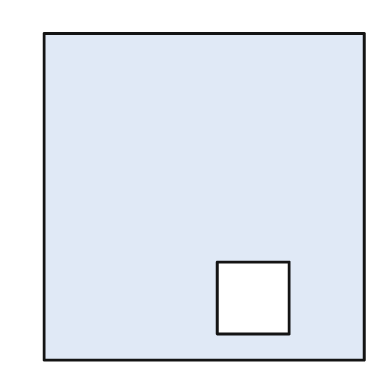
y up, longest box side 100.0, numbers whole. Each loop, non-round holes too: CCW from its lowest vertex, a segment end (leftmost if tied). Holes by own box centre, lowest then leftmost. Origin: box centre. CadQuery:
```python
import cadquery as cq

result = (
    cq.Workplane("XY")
    .moveTo(-49.0, -50.0)
    .lineTo(49.0, -50.0)
    .lineTo(49.0, 50.0)
    .lineTo(-49.0, 50.0)
    .close()
    .moveTo(4.0, -42.0)
    .lineTo(26.0, -42.0)
    .lineTo(26.0, -20.0)
    .lineTo(4.0, -20.0)
    .close()
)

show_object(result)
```